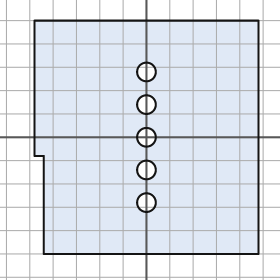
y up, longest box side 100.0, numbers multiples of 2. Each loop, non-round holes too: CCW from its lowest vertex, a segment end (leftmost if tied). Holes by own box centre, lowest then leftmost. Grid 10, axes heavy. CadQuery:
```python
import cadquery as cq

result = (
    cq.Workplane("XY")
    .moveTo(-44.0, -50.0)
    .lineTo(48.0, -50.0)
    .lineTo(48.0, 50.0)
    .lineTo(-48.0, 50.0)
    .lineTo(-48.0, -8.0)
    .lineTo(-44.0, -8.0)
    .close()
    .moveTo(0.0, -28.0)
    .circle(4.0)
    .moveTo(0.0, -14.0)
    .circle(4.0)
    .moveTo(0.0, 0.0)
    .circle(4.0)
    .moveTo(0.0, 14.0)
    .circle(4.0)
    .moveTo(0.0, 28.0)
    .circle(4.0)
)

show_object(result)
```